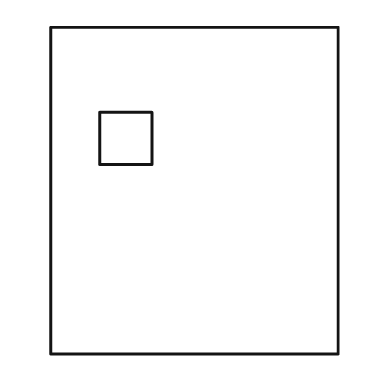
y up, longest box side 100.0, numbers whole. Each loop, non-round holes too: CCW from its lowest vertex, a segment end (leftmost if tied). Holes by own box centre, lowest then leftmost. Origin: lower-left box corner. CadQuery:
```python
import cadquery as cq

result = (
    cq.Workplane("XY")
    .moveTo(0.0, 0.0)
    .lineTo(88.0, 0.0)
    .lineTo(88.0, 100.0)
    .lineTo(0.0, 100.0)
    .close()
    .moveTo(15.0, 58.0)
    .lineTo(31.0, 58.0)
    .lineTo(31.0, 74.0)
    .lineTo(15.0, 74.0)
    .close()
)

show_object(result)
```